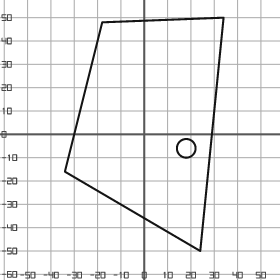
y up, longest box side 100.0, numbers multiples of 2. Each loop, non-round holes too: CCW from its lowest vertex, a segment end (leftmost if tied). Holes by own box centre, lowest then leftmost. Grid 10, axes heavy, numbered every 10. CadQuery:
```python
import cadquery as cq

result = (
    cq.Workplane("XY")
    .moveTo(24.0, -50.0)
    .lineTo(34.0, 50.0)
    .lineTo(-18.0, 48.0)
    .lineTo(-34.0, -16.0)
    .close()
    .moveTo(18.0, -6.0)
    .circle(4.0)
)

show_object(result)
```